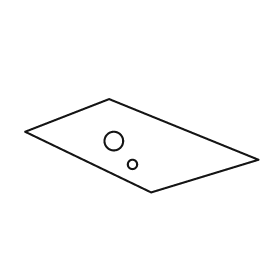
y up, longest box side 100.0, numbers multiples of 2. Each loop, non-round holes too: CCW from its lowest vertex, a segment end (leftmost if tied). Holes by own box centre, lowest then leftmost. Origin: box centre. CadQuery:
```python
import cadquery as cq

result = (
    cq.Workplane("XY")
    .moveTo(4.0, -20.0)
    .lineTo(50.0, -6.0)
    .lineTo(-14.0, 20.0)
    .lineTo(-50.0, 6.0)
    .close()
    .moveTo(-4.0, -8.0)
    .circle(2.0)
    .moveTo(-12.0, 2.0)
    .circle(4.0)
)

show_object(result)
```